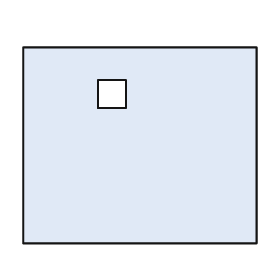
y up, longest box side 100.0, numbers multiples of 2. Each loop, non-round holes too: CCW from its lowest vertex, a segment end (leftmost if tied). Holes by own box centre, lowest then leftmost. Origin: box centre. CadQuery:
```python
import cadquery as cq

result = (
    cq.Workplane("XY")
    .moveTo(-50.0, -42.0)
    .lineTo(50.0, -42.0)
    .lineTo(50.0, 42.0)
    .lineTo(-50.0, 42.0)
    .close()
    .moveTo(-18.0, 16.0)
    .lineTo(-6.0, 16.0)
    .lineTo(-6.0, 28.0)
    .lineTo(-18.0, 28.0)
    .close()
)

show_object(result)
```